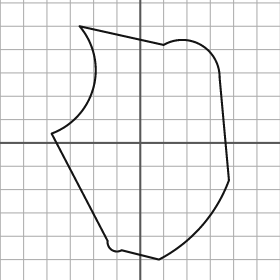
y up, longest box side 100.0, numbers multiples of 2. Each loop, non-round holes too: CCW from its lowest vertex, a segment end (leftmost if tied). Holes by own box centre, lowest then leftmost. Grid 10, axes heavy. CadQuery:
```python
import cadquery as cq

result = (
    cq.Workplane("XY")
    .moveTo(8.0, -50.0)
    .threePointArc((26.0, -36.0), (38.0, -16.0))
    .lineTo(34.0, 28.0)
    .threePointArc((26.0, 42.0), (10.0, 42.0))
    .lineTo(-26.0, 50.0)
    .threePointArc((-20.0, 24.0), (-38.0, 4.0))
    .lineTo(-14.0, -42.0)
    .threePointArc((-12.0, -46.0), (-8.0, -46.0))
    .close()
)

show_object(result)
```